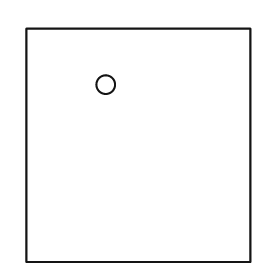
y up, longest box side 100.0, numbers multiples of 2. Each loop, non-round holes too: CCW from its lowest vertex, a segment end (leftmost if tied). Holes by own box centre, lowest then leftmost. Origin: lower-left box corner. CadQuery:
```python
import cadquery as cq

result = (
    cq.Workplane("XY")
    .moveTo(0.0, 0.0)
    .lineTo(96.0, 0.0)
    .lineTo(96.0, 100.0)
    .lineTo(0.0, 100.0)
    .close()
    .moveTo(34.0, 76.0)
    .circle(4.0)
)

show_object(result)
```